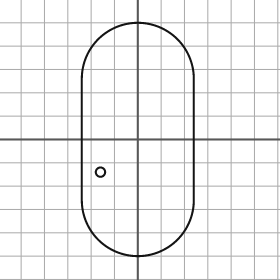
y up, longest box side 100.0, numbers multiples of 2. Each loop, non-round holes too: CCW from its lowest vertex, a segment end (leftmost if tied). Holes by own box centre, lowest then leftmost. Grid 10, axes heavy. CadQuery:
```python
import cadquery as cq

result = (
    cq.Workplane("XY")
    .moveTo(-24.0, -26.0)
    .threePointArc((0.0, -50.0), (24.0, -26.0))
    .lineTo(24.0, 26.0)
    .threePointArc((0.0, 50.0), (-24.0, 26.0))
    .close()
    .moveTo(-16.0, -14.0)
    .circle(2.0)
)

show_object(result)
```